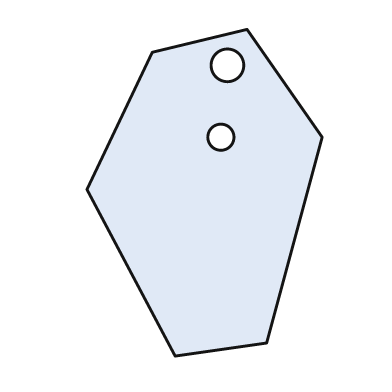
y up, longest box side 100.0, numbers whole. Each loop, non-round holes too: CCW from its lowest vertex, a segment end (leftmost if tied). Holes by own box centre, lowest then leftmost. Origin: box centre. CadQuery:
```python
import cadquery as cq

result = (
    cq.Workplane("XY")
    .moveTo(-9.0, -50.0)
    .lineTo(19.0, -46.0)
    .lineTo(36.0, 17.0)
    .lineTo(13.0, 50.0)
    .lineTo(-16.0, 43.0)
    .lineTo(-36.0, 1.0)
    .close()
    .moveTo(5.0, 17.0)
    .circle(4.0)
    .moveTo(7.0, 39.0)
    .circle(5.0)
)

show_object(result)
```